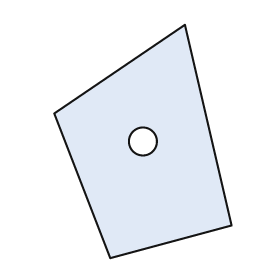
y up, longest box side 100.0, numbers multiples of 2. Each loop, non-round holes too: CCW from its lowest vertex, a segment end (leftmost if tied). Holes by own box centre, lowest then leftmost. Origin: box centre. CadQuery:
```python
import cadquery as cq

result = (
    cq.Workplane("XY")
    .moveTo(-14.0, -50.0)
    .lineTo(38.0, -36.0)
    .lineTo(18.0, 50.0)
    .lineTo(-38.0, 12.0)
    .close()
    .moveTo(0.0, 0.0)
    .circle(6.0)
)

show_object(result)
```